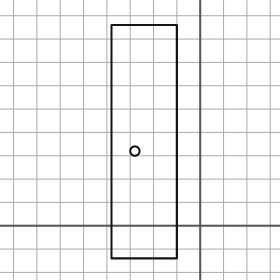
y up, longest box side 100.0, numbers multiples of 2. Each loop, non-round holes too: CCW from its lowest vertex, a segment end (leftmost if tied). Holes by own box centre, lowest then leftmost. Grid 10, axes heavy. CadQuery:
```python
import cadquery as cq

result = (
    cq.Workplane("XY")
    .moveTo(-38.0, -14.0)
    .lineTo(-10.0, -14.0)
    .lineTo(-10.0, 86.0)
    .lineTo(-38.0, 86.0)
    .close()
    .moveTo(-28.0, 32.0)
    .circle(2.0)
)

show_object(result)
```